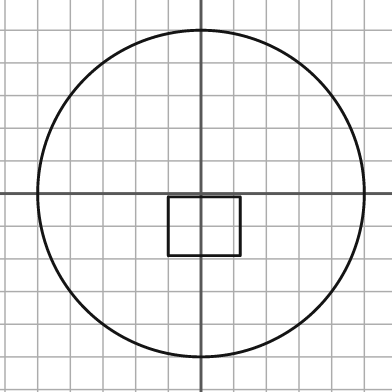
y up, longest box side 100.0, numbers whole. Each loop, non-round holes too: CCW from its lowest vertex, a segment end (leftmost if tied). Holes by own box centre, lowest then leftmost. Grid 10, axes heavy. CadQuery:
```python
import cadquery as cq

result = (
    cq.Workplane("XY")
    .moveTo(0.0, 0.0)
    .circle(50.0)
    .moveTo(-10.0, -19.0)
    .lineTo(12.0, -19.0)
    .lineTo(12.0, -1.0)
    .lineTo(-10.0, -1.0)
    .close()
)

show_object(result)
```